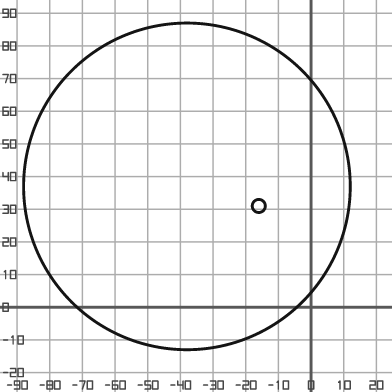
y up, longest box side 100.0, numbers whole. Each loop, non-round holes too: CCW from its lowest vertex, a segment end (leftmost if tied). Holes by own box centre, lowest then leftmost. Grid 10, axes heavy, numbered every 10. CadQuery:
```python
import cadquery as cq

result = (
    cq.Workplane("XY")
    .moveTo(-38.0, 37.0)
    .circle(50.0)
    .moveTo(-16.0, 31.0)
    .circle(2.0)
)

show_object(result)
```